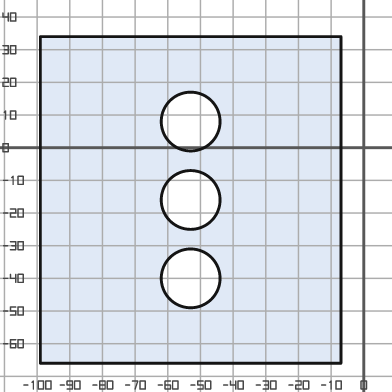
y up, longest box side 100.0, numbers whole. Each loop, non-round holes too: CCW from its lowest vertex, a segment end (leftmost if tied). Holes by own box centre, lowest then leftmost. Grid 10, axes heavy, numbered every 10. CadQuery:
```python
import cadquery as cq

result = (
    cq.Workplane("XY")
    .moveTo(-99.0, -66.0)
    .lineTo(-7.0, -66.0)
    .lineTo(-7.0, 34.0)
    .lineTo(-99.0, 34.0)
    .close()
    .moveTo(-53.0, -40.0)
    .circle(9.0)
    .moveTo(-53.0, -16.0)
    .circle(9.0)
    .moveTo(-53.0, 8.0)
    .circle(9.0)
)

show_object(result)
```